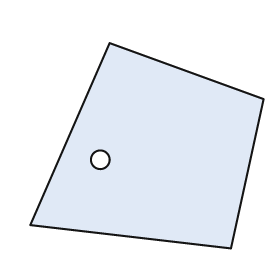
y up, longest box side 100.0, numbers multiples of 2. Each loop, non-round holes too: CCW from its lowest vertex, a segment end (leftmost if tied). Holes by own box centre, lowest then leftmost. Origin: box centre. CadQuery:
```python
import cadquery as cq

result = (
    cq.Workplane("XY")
    .moveTo(36.0, -44.0)
    .lineTo(50.0, 20.0)
    .lineTo(-16.0, 44.0)
    .lineTo(-50.0, -34.0)
    .close()
    .moveTo(-20.0, -6.0)
    .circle(4.0)
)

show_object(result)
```